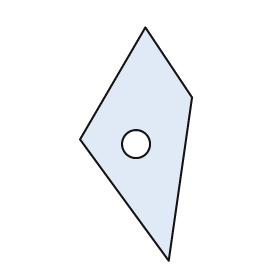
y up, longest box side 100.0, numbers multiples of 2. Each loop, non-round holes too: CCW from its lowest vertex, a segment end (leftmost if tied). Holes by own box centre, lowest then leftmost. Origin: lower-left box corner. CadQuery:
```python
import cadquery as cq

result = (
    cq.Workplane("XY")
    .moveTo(38.0, 0.0)
    .lineTo(48.0, 70.0)
    .lineTo(28.0, 100.0)
    .lineTo(0.0, 52.0)
    .close()
    .moveTo(24.0, 50.0)
    .circle(6.0)
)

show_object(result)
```